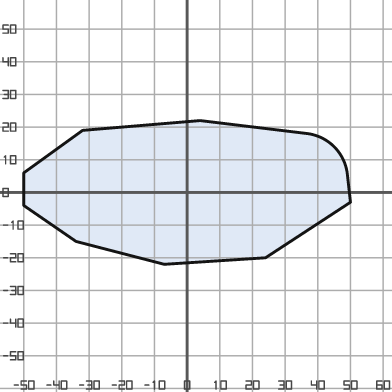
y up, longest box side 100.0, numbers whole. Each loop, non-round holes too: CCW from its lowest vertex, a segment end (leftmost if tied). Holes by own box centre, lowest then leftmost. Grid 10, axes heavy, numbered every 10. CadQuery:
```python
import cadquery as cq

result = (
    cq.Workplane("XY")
    .moveTo(-7.0, -22.0)
    .lineTo(24.0, -20.0)
    .lineTo(50.0, -3.0)
    .lineTo(49.0, 6.0)
    .threePointArc((45.0, 14.0), (37.0, 18.0))
    .lineTo(4.0, 22.0)
    .lineTo(-32.0, 19.0)
    .lineTo(-50.0, 6.0)
    .lineTo(-50.0, -4.0)
    .lineTo(-34.0, -15.0)
    .close()
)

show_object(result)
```